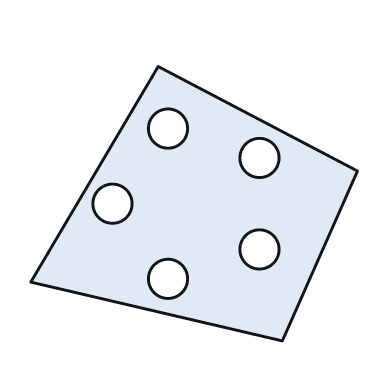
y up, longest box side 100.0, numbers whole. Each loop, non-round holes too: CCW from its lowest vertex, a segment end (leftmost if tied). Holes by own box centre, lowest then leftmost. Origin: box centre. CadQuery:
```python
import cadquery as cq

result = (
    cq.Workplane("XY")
    .moveTo(27.0, -42.0)
    .lineTo(50.0, 10.0)
    .lineTo(-11.0, 42.0)
    .lineTo(-50.0, -24.0)
    .close()
    .moveTo(-8.0, -23.0)
    .circle(6.0)
    .moveTo(20.0, -14.0)
    .circle(6.0)
    .moveTo(-25.0, 0.0)
    .circle(6.0)
    .moveTo(20.0, 14.0)
    .circle(6.0)
    .moveTo(-8.0, 23.0)
    .circle(6.0)
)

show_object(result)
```